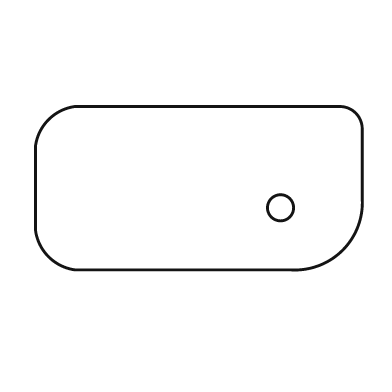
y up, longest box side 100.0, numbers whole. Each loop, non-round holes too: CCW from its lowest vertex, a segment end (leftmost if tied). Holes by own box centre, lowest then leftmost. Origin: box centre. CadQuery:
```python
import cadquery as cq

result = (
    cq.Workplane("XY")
    .moveTo(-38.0, -25.0)
    .lineTo(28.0, -25.0)
    .threePointArc((44.0, -19.0), (50.0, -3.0))
    .lineTo(50.0, 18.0)
    .threePointArc((48.0, 23.0), (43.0, 25.0))
    .lineTo(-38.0, 25.0)
    .threePointArc((-46.0, 21.0), (-50.0, 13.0))
    .lineTo(-50.0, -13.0)
    .threePointArc((-46.0, -21.0), (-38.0, -25.0))
    .close()
    .moveTo(25.0, -6.0)
    .circle(4.0)
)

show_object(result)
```